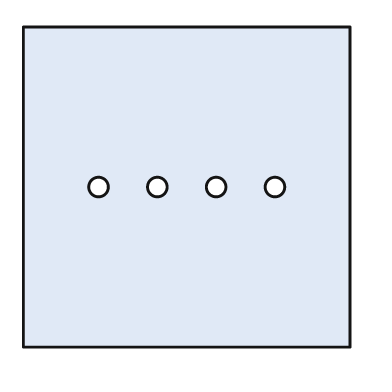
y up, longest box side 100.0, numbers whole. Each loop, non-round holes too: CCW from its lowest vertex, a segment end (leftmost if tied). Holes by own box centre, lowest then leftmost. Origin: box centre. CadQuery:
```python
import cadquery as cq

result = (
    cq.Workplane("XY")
    .moveTo(-50.0, -49.0)
    .lineTo(50.0, -49.0)
    .lineTo(50.0, 49.0)
    .lineTo(-50.0, 49.0)
    .close()
    .moveTo(-27.0, 0.0)
    .circle(3.0)
    .moveTo(-9.0, 0.0)
    .circle(3.0)
    .moveTo(9.0, 0.0)
    .circle(3.0)
    .moveTo(27.0, 0.0)
    .circle(3.0)
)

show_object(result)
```